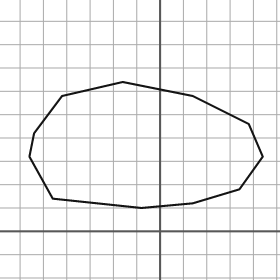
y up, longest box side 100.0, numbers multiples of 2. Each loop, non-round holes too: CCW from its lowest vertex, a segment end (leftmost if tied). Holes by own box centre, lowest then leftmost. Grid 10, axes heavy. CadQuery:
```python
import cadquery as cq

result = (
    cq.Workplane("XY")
    .moveTo(-8.0, 10.0)
    .lineTo(14.0, 12.0)
    .lineTo(34.0, 18.0)
    .lineTo(44.0, 32.0)
    .lineTo(38.0, 46.0)
    .lineTo(14.0, 58.0)
    .lineTo(-16.0, 64.0)
    .lineTo(-42.0, 58.0)
    .lineTo(-54.0, 42.0)
    .lineTo(-56.0, 32.0)
    .lineTo(-46.0, 14.0)
    .close()
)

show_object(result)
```